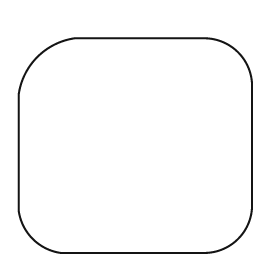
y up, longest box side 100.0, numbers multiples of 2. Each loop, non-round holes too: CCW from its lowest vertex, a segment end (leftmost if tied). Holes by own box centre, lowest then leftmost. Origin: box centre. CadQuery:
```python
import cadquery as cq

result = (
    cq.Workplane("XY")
    .moveTo(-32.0, -46.0)
    .lineTo(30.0, -46.0)
    .threePointArc((44.0, -40.0), (50.0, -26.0))
    .lineTo(50.0, 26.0)
    .threePointArc((44.0, 40.0), (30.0, 46.0))
    .lineTo(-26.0, 46.0)
    .threePointArc((-42.0, 38.0), (-50.0, 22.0))
    .lineTo(-50.0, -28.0)
    .threePointArc((-44.0, -40.0), (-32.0, -46.0))
    .close()
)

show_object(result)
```